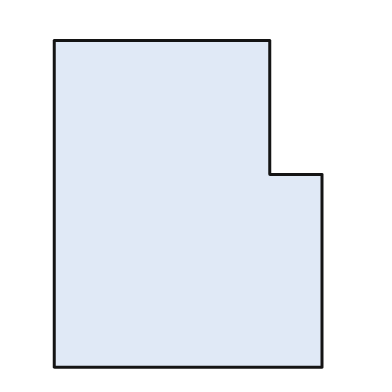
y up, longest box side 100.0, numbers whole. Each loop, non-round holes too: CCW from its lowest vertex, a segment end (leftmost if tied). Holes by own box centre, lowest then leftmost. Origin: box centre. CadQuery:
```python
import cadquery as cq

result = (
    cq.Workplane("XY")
    .moveTo(-41.0, -50.0)
    .lineTo(41.0, -50.0)
    .lineTo(41.0, 9.0)
    .lineTo(25.0, 9.0)
    .lineTo(25.0, 50.0)
    .lineTo(-41.0, 50.0)
    .close()
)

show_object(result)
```